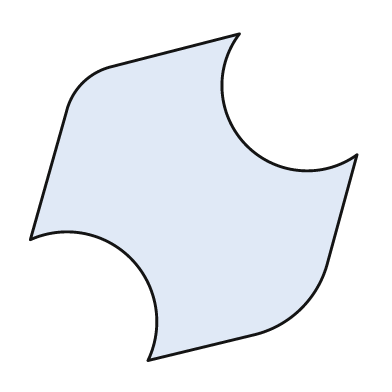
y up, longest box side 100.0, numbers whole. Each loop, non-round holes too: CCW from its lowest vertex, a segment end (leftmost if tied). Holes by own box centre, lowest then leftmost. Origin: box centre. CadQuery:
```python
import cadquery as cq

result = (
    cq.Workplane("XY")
    .moveTo(-14.0, -50.0)
    .lineTo(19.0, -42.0)
    .threePointArc((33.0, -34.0), (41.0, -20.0))
    .lineTo(50.0, 13.0)
    .threePointArc((16.0, 16.0), (14.0, 50.0))
    .lineTo(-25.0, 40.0)
    .threePointArc((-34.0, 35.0), (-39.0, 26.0))
    .lineTo(-50.0, -13.0)
    .threePointArc((-19.0, -19.0), (-14.0, -50.0))
    .close()
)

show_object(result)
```